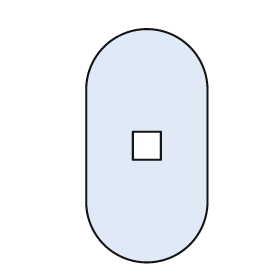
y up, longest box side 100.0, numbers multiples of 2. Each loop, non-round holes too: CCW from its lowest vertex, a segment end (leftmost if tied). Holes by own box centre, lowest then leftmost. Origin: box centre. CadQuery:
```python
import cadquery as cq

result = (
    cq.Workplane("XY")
    .moveTo(-26.0, -24.0)
    .threePointArc((0.0, -50.0), (26.0, -24.0))
    .lineTo(26.0, 24.0)
    .threePointArc((0.0, 50.0), (-26.0, 24.0))
    .close()
    .moveTo(-6.0, -6.0)
    .lineTo(6.0, -6.0)
    .lineTo(6.0, 6.0)
    .lineTo(-6.0, 6.0)
    .close()
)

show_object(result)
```